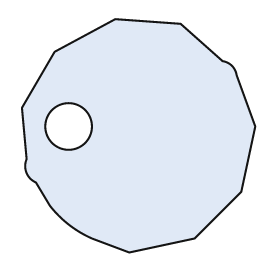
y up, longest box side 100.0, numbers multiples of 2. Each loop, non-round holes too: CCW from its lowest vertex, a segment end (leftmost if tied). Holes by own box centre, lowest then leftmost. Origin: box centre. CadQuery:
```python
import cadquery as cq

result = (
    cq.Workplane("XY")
    .moveTo(-4.0, -50.0)
    .lineTo(24.0, -44.0)
    .lineTo(44.0, -24.0)
    .lineTo(50.0, 4.0)
    .lineTo(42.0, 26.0)
    .threePointArc((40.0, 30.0), (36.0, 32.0))
    .lineTo(18.0, 48.0)
    .lineTo(-10.0, 50.0)
    .lineTo(-36.0, 36.0)
    .lineTo(-50.0, 12.0)
    .lineTo(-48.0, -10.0)
    .threePointArc((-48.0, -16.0), (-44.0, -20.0))
    .lineTo(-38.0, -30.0)
    .threePointArc((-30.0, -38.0), (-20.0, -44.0))
    .close()
    .moveTo(-30.0, 4.0)
    .circle(10.0)
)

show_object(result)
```